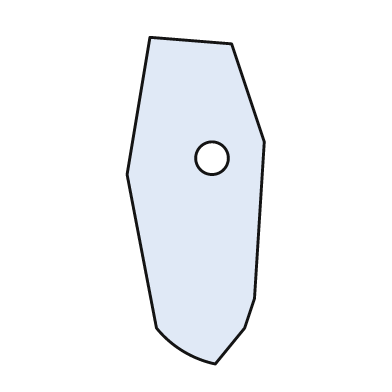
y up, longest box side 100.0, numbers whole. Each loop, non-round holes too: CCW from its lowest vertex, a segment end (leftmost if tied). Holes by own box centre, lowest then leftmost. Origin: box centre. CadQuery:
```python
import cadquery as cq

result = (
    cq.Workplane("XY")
    .moveTo(6.0, -50.0)
    .lineTo(15.0, -39.0)
    .lineTo(18.0, -30.0)
    .lineTo(21.0, 18.0)
    .lineTo(11.0, 48.0)
    .lineTo(-14.0, 50.0)
    .lineTo(-21.0, 8.0)
    .lineTo(-12.0, -39.0)
    .threePointArc((-4.0, -46.0), (6.0, -50.0))
    .close()
    .moveTo(5.0, 13.0)
    .circle(5.0)
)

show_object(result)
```